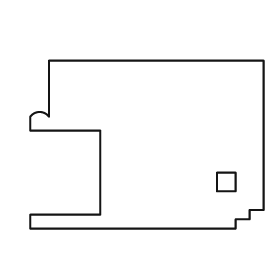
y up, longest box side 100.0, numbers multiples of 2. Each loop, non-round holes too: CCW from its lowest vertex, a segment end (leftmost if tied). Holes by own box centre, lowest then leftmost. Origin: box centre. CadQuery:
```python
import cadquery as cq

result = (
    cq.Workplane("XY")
    .moveTo(-50.0, -36.0)
    .lineTo(38.0, -36.0)
    .lineTo(38.0, -32.0)
    .lineTo(44.0, -32.0)
    .lineTo(44.0, -28.0)
    .lineTo(50.0, -28.0)
    .lineTo(50.0, 36.0)
    .lineTo(-42.0, 36.0)
    .lineTo(-42.0, 12.0)
    .threePointArc((-46.0, 14.0), (-50.0, 12.0))
    .lineTo(-50.0, 6.0)
    .lineTo(-20.0, 6.0)
    .lineTo(-20.0, -30.0)
    .lineTo(-50.0, -30.0)
    .close()
    .moveTo(30.0, -20.0)
    .lineTo(38.0, -20.0)
    .lineTo(38.0, -12.0)
    .lineTo(30.0, -12.0)
    .close()
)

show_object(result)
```